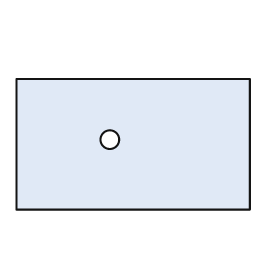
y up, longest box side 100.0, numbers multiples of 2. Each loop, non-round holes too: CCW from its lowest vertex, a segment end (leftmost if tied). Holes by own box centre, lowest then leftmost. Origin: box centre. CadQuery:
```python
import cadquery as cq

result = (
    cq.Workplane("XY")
    .moveTo(-50.0, -28.0)
    .lineTo(50.0, -28.0)
    .lineTo(50.0, 28.0)
    .lineTo(-50.0, 28.0)
    .close()
    .moveTo(-10.0, 2.0)
    .circle(4.0)
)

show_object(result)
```